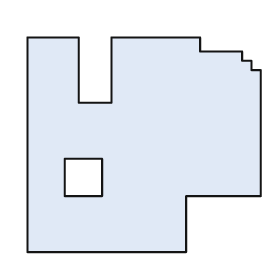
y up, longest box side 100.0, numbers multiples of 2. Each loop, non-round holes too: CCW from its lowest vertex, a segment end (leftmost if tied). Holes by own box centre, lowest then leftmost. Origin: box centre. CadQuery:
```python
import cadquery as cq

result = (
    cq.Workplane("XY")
    .moveTo(-50.0, -46.0)
    .lineTo(18.0, -46.0)
    .lineTo(18.0, -22.0)
    .lineTo(50.0, -22.0)
    .lineTo(50.0, 32.0)
    .lineTo(46.0, 32.0)
    .lineTo(46.0, 36.0)
    .lineTo(42.0, 36.0)
    .lineTo(42.0, 40.0)
    .lineTo(24.0, 40.0)
    .lineTo(24.0, 46.0)
    .lineTo(-14.0, 46.0)
    .lineTo(-14.0, 18.0)
    .lineTo(-28.0, 18.0)
    .lineTo(-28.0, 46.0)
    .lineTo(-50.0, 46.0)
    .close()
    .moveTo(-34.0, -22.0)
    .lineTo(-18.0, -22.0)
    .lineTo(-18.0, -6.0)
    .lineTo(-34.0, -6.0)
    .close()
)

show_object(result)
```